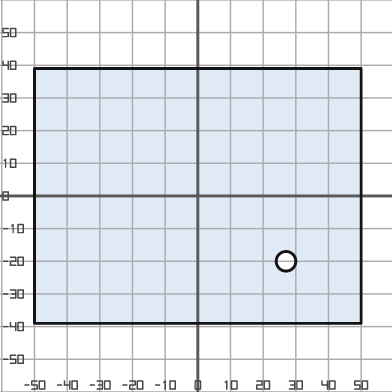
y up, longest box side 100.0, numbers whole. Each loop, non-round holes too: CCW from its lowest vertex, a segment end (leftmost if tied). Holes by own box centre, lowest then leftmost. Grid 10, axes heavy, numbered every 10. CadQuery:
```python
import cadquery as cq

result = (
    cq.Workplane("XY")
    .moveTo(-50.0, -39.0)
    .lineTo(50.0, -39.0)
    .lineTo(50.0, 39.0)
    .lineTo(-50.0, 39.0)
    .close()
    .moveTo(27.0, -20.0)
    .circle(3.0)
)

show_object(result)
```